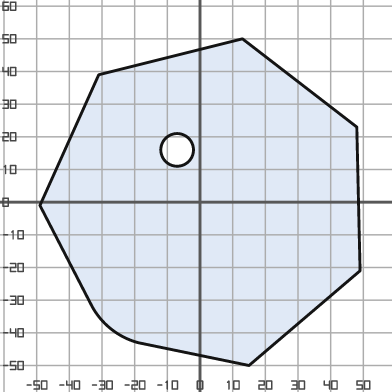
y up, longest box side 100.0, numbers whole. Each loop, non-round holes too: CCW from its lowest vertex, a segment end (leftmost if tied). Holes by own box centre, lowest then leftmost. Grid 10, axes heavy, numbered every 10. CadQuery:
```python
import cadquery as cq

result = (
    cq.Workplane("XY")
    .moveTo(15.0, -50.0)
    .lineTo(49.0, -21.0)
    .lineTo(48.0, 23.0)
    .lineTo(13.0, 50.0)
    .lineTo(-31.0, 39.0)
    .lineTo(-49.0, -1.0)
    .lineTo(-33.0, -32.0)
    .threePointArc((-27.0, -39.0), (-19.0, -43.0))
    .close()
    .moveTo(-7.0, 16.0)
    .circle(5.0)
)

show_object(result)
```